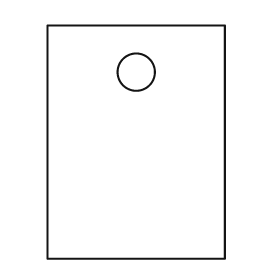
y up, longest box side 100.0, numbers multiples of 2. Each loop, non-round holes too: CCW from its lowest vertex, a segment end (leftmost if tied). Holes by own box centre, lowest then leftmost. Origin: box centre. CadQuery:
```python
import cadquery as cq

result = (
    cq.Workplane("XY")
    .moveTo(-38.0, -50.0)
    .lineTo(38.0, -50.0)
    .lineTo(38.0, 50.0)
    .lineTo(-38.0, 50.0)
    .close()
    .moveTo(0.0, 30.0)
    .circle(8.0)
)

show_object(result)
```